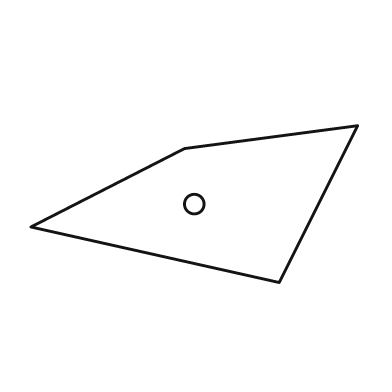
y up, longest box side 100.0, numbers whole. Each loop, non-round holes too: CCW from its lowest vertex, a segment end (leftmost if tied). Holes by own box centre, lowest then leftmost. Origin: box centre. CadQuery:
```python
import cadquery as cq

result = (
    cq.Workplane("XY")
    .moveTo(26.0, -24.0)
    .lineTo(50.0, 24.0)
    .lineTo(-3.0, 17.0)
    .lineTo(-50.0, -7.0)
    .close()
    .moveTo(0.0, 0.0)
    .circle(3.0)
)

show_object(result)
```